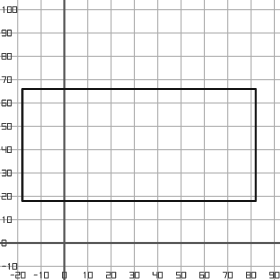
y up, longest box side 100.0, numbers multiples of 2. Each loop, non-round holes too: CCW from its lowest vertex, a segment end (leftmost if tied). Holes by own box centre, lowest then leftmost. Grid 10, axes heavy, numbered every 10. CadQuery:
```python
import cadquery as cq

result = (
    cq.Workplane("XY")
    .moveTo(-18.0, 18.0)
    .lineTo(82.0, 18.0)
    .lineTo(82.0, 66.0)
    .lineTo(-18.0, 66.0)
    .close()
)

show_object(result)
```